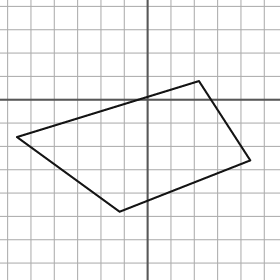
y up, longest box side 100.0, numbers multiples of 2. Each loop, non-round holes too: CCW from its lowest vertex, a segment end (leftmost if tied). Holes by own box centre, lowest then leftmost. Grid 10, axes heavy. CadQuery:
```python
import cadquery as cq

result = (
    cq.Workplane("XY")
    .moveTo(-12.0, -48.0)
    .lineTo(44.0, -26.0)
    .lineTo(22.0, 8.0)
    .lineTo(-56.0, -16.0)
    .close()
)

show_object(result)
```